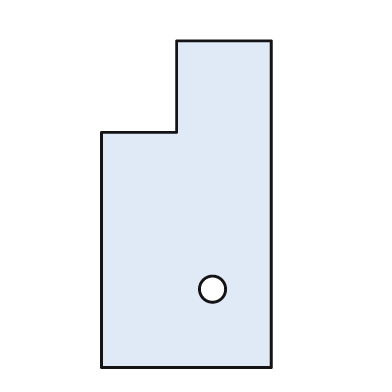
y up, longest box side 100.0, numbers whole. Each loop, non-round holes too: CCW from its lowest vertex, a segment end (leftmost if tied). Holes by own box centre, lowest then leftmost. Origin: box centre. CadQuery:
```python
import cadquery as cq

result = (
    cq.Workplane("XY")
    .moveTo(-26.0, -50.0)
    .lineTo(26.0, -50.0)
    .lineTo(26.0, 50.0)
    .lineTo(-3.0, 50.0)
    .lineTo(-3.0, 22.0)
    .lineTo(-26.0, 22.0)
    .close()
    .moveTo(8.0, -26.0)
    .circle(4.0)
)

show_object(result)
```